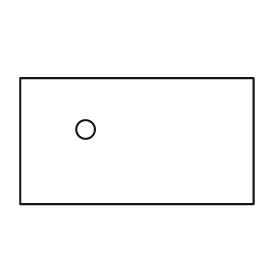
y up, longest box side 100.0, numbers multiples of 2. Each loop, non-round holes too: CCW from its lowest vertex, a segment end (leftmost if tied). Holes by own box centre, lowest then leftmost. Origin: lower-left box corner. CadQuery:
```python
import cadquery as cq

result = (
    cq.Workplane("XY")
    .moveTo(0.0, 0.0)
    .lineTo(100.0, 0.0)
    .lineTo(100.0, 54.0)
    .lineTo(0.0, 54.0)
    .close()
    .moveTo(28.0, 32.0)
    .circle(4.0)
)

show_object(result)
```